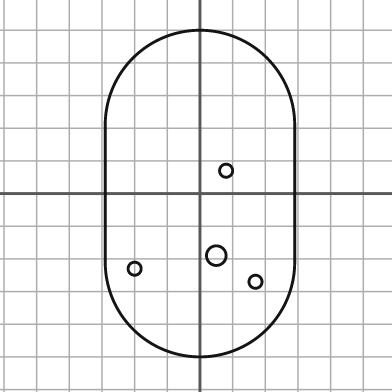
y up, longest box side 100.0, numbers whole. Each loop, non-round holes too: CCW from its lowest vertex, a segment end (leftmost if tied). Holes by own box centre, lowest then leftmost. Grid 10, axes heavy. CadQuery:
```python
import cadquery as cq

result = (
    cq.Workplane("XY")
    .moveTo(-29.0, -21.0)
    .threePointArc((0.0, -50.0), (29.0, -21.0))
    .lineTo(29.0, 21.0)
    .threePointArc((0.0, 50.0), (-29.0, 21.0))
    .close()
    .moveTo(17.0, -27.0)
    .circle(2.0)
    .moveTo(-20.0, -23.0)
    .circle(2.0)
    .moveTo(5.0, -19.0)
    .circle(3.0)
    .moveTo(8.0, 7.0)
    .circle(2.0)
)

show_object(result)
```